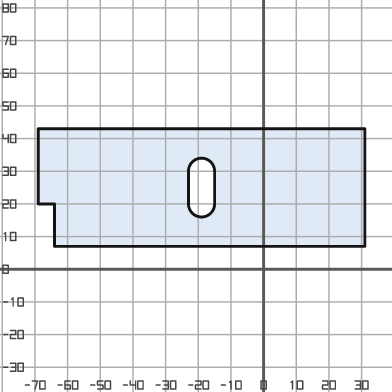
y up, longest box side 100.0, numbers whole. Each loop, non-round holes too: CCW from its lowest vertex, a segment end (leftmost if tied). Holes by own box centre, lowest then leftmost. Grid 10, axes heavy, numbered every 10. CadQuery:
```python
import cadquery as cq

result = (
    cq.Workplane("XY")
    .moveTo(-64.0, 7.0)
    .lineTo(31.0, 7.0)
    .lineTo(31.0, 43.0)
    .lineTo(-69.0, 43.0)
    .lineTo(-69.0, 20.0)
    .lineTo(-64.0, 20.0)
    .close()
    .moveTo(-23.0, 20.0)
    .threePointArc((-19.0, 16.0), (-15.0, 20.0))
    .lineTo(-15.0, 30.0)
    .threePointArc((-19.0, 34.0), (-23.0, 30.0))
    .close()
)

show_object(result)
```